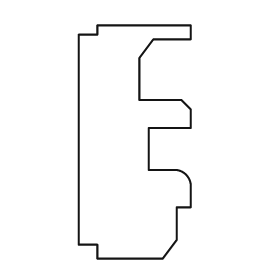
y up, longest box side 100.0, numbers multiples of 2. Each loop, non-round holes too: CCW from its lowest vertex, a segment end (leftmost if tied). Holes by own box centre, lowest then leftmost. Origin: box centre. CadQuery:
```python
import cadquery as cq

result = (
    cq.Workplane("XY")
    .moveTo(-16.0, -50.0)
    .lineTo(12.0, -50.0)
    .lineTo(18.0, -42.0)
    .lineTo(18.0, -28.0)
    .lineTo(24.0, -28.0)
    .lineTo(24.0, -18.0)
    .threePointArc((22.0, -14.0), (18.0, -12.0))
    .lineTo(6.0, -12.0)
    .lineTo(6.0, 6.0)
    .lineTo(24.0, 6.0)
    .lineTo(24.0, 14.0)
    .lineTo(20.0, 18.0)
    .lineTo(2.0, 18.0)
    .lineTo(2.0, 36.0)
    .lineTo(8.0, 44.0)
    .lineTo(24.0, 44.0)
    .lineTo(24.0, 50.0)
    .lineTo(-16.0, 50.0)
    .lineTo(-16.0, 46.0)
    .lineTo(-24.0, 46.0)
    .lineTo(-24.0, -44.0)
    .lineTo(-16.0, -44.0)
    .close()
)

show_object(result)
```